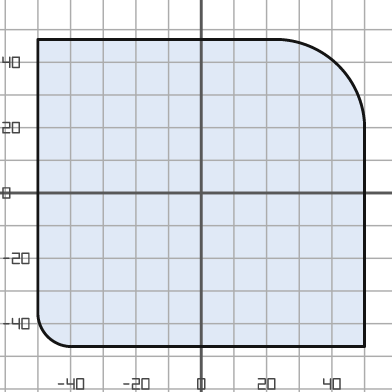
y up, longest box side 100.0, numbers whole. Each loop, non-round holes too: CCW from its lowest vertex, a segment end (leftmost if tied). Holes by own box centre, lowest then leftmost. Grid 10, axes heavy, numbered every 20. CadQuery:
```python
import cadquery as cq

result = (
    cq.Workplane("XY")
    .moveTo(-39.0, -47.0)
    .lineTo(50.0, -47.0)
    .lineTo(50.0, 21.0)
    .threePointArc((42.0, 39.0), (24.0, 47.0))
    .lineTo(-50.0, 47.0)
    .lineTo(-50.0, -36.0)
    .threePointArc((-47.0, -44.0), (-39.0, -47.0))
    .close()
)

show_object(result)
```